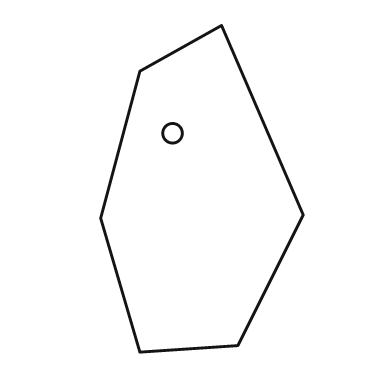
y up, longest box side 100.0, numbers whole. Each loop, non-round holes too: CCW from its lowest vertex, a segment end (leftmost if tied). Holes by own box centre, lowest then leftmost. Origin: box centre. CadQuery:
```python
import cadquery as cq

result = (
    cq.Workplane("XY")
    .moveTo(-19.0, -50.0)
    .lineTo(11.0, -48.0)
    .lineTo(31.0, -8.0)
    .lineTo(6.0, 50.0)
    .lineTo(-19.0, 36.0)
    .lineTo(-31.0, -9.0)
    .close()
    .moveTo(-9.0, 17.0)
    .circle(3.0)
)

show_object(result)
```